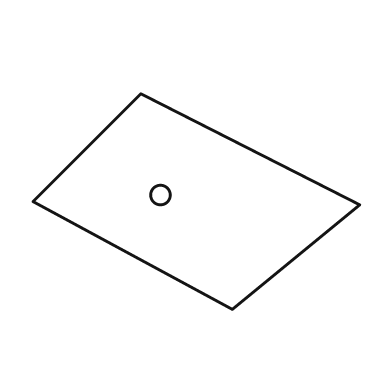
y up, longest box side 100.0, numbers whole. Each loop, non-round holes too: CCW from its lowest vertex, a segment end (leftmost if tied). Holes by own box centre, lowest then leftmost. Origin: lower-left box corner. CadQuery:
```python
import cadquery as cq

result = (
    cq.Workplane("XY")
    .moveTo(61.0, 0.0)
    .lineTo(100.0, 32.0)
    .lineTo(33.0, 66.0)
    .lineTo(0.0, 33.0)
    .close()
    .moveTo(39.0, 35.0)
    .circle(3.0)
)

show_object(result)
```